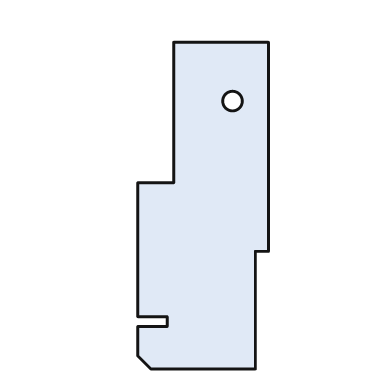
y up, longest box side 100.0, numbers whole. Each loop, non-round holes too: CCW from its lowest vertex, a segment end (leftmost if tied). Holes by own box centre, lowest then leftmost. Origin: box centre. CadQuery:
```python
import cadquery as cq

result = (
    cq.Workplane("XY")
    .moveTo(-16.0, -50.0)
    .lineTo(16.0, -50.0)
    .lineTo(16.0, -14.0)
    .lineTo(20.0, -14.0)
    .lineTo(20.0, 50.0)
    .lineTo(-9.0, 50.0)
    .lineTo(-9.0, 7.0)
    .lineTo(-20.0, 7.0)
    .lineTo(-20.0, -34.0)
    .lineTo(-11.0, -34.0)
    .lineTo(-11.0, -37.0)
    .lineTo(-20.0, -37.0)
    .lineTo(-20.0, -46.0)
    .close()
    .moveTo(9.0, 32.0)
    .circle(3.0)
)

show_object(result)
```